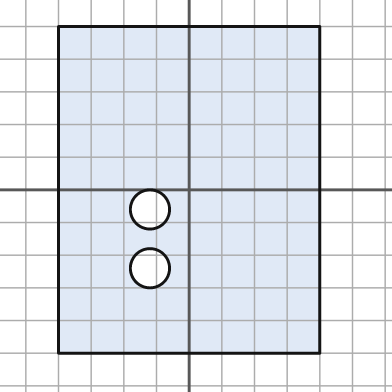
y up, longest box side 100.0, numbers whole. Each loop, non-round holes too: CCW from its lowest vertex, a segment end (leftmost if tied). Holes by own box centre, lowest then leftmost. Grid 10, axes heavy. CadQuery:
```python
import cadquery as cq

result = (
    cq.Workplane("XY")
    .moveTo(-40.0, -50.0)
    .lineTo(40.0, -50.0)
    .lineTo(40.0, 50.0)
    .lineTo(-40.0, 50.0)
    .close()
    .moveTo(-12.0, -24.0)
    .circle(6.0)
    .moveTo(-12.0, -6.0)
    .circle(6.0)
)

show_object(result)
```